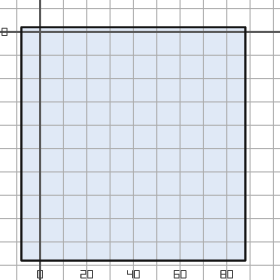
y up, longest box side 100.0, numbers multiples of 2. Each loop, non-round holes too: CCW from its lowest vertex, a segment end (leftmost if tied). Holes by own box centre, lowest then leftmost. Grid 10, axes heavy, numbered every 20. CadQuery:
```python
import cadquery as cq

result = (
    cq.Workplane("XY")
    .moveTo(-8.0, -98.0)
    .lineTo(88.0, -98.0)
    .lineTo(88.0, 2.0)
    .lineTo(-8.0, 2.0)
    .close()
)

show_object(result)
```